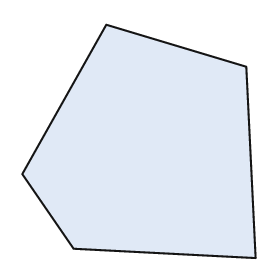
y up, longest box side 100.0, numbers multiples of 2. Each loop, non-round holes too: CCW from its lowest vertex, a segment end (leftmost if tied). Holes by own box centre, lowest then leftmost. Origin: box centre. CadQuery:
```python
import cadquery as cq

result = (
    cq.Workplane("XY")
    .moveTo(50.0, -50.0)
    .lineTo(46.0, 32.0)
    .lineTo(-14.0, 50.0)
    .lineTo(-50.0, -14.0)
    .lineTo(-28.0, -46.0)
    .close()
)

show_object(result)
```